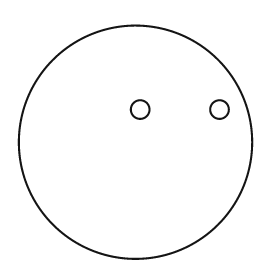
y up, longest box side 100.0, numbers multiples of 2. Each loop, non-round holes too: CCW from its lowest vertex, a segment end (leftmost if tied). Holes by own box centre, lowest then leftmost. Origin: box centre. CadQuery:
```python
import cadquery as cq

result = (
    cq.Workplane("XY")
    .moveTo(0.0, 0.0)
    .circle(50.0)
    .moveTo(2.0, 14.0)
    .circle(4.0)
    .moveTo(36.0, 14.0)
    .circle(4.0)
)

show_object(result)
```